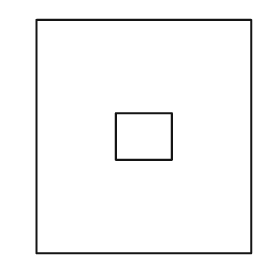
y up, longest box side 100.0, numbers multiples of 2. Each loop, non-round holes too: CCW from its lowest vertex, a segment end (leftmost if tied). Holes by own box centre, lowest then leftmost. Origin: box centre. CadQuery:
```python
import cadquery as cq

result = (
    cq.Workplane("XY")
    .moveTo(-46.0, -50.0)
    .lineTo(46.0, -50.0)
    .lineTo(46.0, 50.0)
    .lineTo(-46.0, 50.0)
    .close()
    .moveTo(-12.0, -10.0)
    .lineTo(12.0, -10.0)
    .lineTo(12.0, 10.0)
    .lineTo(-12.0, 10.0)
    .close()
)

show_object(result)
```